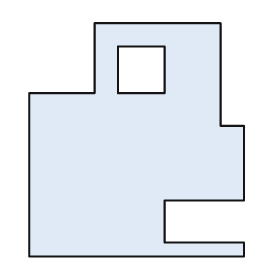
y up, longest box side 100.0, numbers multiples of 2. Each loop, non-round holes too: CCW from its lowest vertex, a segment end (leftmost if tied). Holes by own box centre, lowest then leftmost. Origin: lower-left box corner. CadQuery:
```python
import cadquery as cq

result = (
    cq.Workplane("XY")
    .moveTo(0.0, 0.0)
    .lineTo(92.0, 0.0)
    .lineTo(92.0, 6.0)
    .lineTo(58.0, 6.0)
    .lineTo(58.0, 24.0)
    .lineTo(92.0, 24.0)
    .lineTo(92.0, 56.0)
    .lineTo(82.0, 56.0)
    .lineTo(82.0, 100.0)
    .lineTo(28.0, 100.0)
    .lineTo(28.0, 70.0)
    .lineTo(0.0, 70.0)
    .close()
    .moveTo(38.0, 70.0)
    .lineTo(58.0, 70.0)
    .lineTo(58.0, 90.0)
    .lineTo(38.0, 90.0)
    .close()
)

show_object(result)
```